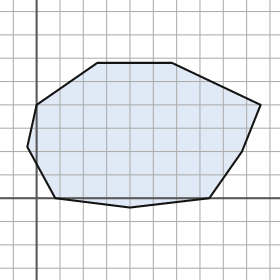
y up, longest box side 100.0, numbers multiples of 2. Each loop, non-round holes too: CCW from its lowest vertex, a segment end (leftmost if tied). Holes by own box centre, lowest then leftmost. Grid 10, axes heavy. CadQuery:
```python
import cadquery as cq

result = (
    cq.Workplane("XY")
    .moveTo(40.0, -4.0)
    .lineTo(74.0, 0.0)
    .lineTo(88.0, 20.0)
    .lineTo(96.0, 40.0)
    .lineTo(58.0, 58.0)
    .lineTo(26.0, 58.0)
    .lineTo(0.0, 40.0)
    .lineTo(-4.0, 22.0)
    .lineTo(8.0, 0.0)
    .close()
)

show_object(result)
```